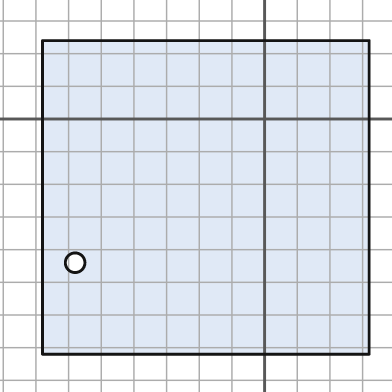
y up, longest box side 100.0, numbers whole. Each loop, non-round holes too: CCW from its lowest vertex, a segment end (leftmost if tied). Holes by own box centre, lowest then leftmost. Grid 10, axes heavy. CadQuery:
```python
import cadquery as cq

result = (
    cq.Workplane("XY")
    .moveTo(-68.0, -72.0)
    .lineTo(32.0, -72.0)
    .lineTo(32.0, 24.0)
    .lineTo(-68.0, 24.0)
    .close()
    .moveTo(-58.0, -44.0)
    .circle(3.0)
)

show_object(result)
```